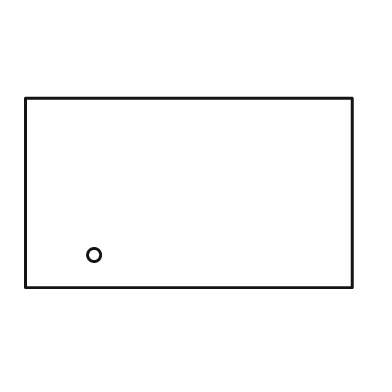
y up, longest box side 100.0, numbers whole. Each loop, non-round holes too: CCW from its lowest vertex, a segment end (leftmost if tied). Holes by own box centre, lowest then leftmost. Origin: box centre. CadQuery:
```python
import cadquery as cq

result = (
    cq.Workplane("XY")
    .moveTo(-50.0, -29.0)
    .lineTo(50.0, -29.0)
    .lineTo(50.0, 29.0)
    .lineTo(-50.0, 29.0)
    .close()
    .moveTo(-29.0, -19.0)
    .circle(2.0)
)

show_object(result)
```